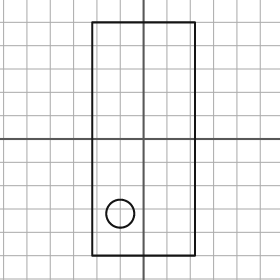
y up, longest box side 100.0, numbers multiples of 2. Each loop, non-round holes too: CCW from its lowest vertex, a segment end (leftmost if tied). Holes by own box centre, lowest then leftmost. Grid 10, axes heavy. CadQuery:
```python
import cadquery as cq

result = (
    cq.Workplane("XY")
    .moveTo(-22.0, -50.0)
    .lineTo(22.0, -50.0)
    .lineTo(22.0, 50.0)
    .lineTo(-22.0, 50.0)
    .close()
    .moveTo(-10.0, -32.0)
    .circle(6.0)
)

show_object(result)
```